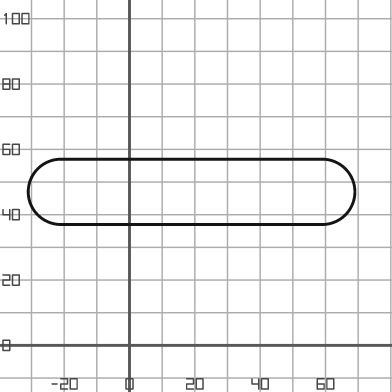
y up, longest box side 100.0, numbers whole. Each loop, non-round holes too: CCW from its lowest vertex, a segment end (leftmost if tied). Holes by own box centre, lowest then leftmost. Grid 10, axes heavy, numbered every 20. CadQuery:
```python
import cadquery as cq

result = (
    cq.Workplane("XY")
    .moveTo(-21.0, 37.0)
    .lineTo(59.0, 37.0)
    .threePointArc((69.0, 47.0), (59.0, 57.0))
    .lineTo(-21.0, 57.0)
    .threePointArc((-31.0, 47.0), (-21.0, 37.0))
    .close()
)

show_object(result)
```